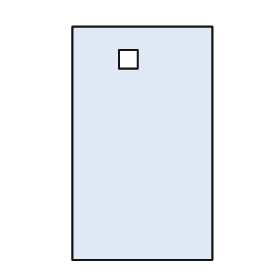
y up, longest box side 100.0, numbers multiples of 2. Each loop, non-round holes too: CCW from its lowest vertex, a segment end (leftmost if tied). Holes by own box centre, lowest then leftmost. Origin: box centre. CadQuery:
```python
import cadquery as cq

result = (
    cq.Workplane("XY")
    .moveTo(-30.0, -50.0)
    .lineTo(30.0, -50.0)
    .lineTo(30.0, 50.0)
    .lineTo(-30.0, 50.0)
    .close()
    .moveTo(-10.0, 32.0)
    .lineTo(-2.0, 32.0)
    .lineTo(-2.0, 40.0)
    .lineTo(-10.0, 40.0)
    .close()
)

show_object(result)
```